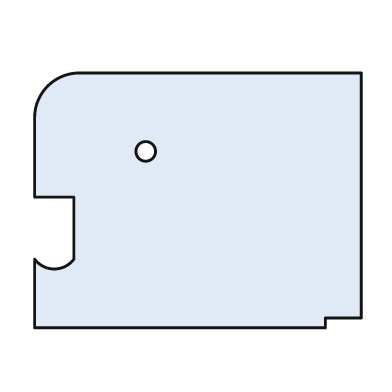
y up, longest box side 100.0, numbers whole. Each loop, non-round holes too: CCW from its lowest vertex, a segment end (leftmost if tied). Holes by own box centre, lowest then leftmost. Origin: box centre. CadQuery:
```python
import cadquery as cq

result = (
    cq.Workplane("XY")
    .moveTo(-50.0, -39.0)
    .lineTo(39.0, -39.0)
    .lineTo(39.0, -36.0)
    .lineTo(50.0, -36.0)
    .lineTo(50.0, 39.0)
    .lineTo(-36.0, 39.0)
    .threePointArc((-46.0, 35.0), (-50.0, 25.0))
    .lineTo(-50.0, 1.0)
    .lineTo(-38.0, 1.0)
    .lineTo(-38.0, -18.0)
    .threePointArc((-44.0, -21.0), (-50.0, -18.0))
    .close()
    .moveTo(-16.0, 15.0)
    .circle(3.0)
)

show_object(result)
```